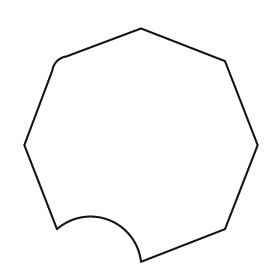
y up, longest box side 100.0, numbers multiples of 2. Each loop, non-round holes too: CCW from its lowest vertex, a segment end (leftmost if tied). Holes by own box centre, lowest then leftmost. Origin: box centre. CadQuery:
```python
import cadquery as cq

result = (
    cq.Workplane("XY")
    .moveTo(0.0, -50.0)
    .lineTo(36.0, -36.0)
    .lineTo(50.0, 0.0)
    .lineTo(36.0, 36.0)
    .lineTo(0.0, 50.0)
    .lineTo(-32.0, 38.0)
    .threePointArc((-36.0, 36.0), (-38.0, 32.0))
    .lineTo(-50.0, 0.0)
    .lineTo(-36.0, -36.0)
    .threePointArc((-14.0, -32.0), (0.0, -50.0))
    .close()
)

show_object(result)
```